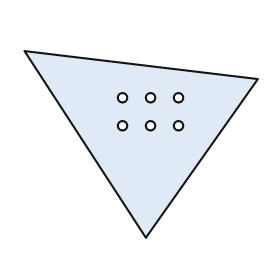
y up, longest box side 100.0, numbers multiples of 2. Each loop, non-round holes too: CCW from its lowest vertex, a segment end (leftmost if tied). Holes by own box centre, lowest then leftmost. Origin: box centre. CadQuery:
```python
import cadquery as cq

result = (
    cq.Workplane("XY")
    .moveTo(2.0, -40.0)
    .lineTo(50.0, 28.0)
    .lineTo(-50.0, 40.0)
    .close()
    .moveTo(-8.0, 8.0)
    .circle(2.0)
    .moveTo(4.0, 8.0)
    .circle(2.0)
    .moveTo(16.0, 8.0)
    .circle(2.0)
    .moveTo(-8.0, 20.0)
    .circle(2.0)
    .moveTo(4.0, 20.0)
    .circle(2.0)
    .moveTo(16.0, 20.0)
    .circle(2.0)
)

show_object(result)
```